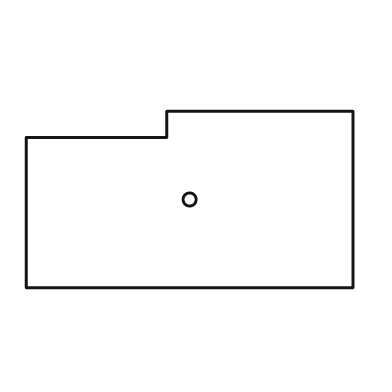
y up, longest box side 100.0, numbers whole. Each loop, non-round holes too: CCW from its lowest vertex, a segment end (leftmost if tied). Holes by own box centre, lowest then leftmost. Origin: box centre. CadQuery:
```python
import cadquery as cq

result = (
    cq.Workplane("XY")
    .moveTo(-50.0, -27.0)
    .lineTo(50.0, -27.0)
    .lineTo(50.0, 27.0)
    .lineTo(-7.0, 27.0)
    .lineTo(-7.0, 19.0)
    .lineTo(-50.0, 19.0)
    .close()
    .moveTo(0.0, 0.0)
    .circle(2.0)
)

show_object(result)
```